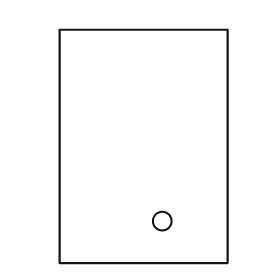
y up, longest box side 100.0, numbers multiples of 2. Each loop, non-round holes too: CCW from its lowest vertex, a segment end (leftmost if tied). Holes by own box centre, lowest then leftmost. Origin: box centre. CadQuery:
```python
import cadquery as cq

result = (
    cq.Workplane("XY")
    .moveTo(-36.0, -50.0)
    .lineTo(36.0, -50.0)
    .lineTo(36.0, 50.0)
    .lineTo(-36.0, 50.0)
    .close()
    .moveTo(8.0, -32.0)
    .circle(4.0)
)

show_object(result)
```